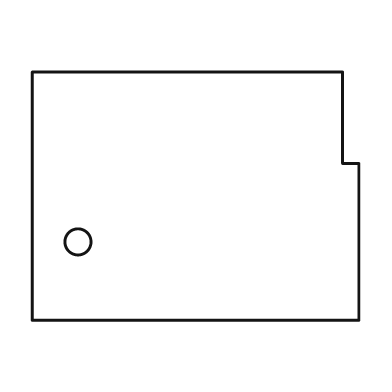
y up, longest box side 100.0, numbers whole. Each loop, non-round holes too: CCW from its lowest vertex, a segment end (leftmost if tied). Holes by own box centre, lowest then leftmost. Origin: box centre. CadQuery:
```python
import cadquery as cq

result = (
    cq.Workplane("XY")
    .moveTo(-50.0, -38.0)
    .lineTo(50.0, -38.0)
    .lineTo(50.0, 10.0)
    .lineTo(45.0, 10.0)
    .lineTo(45.0, 38.0)
    .lineTo(-50.0, 38.0)
    .close()
    .moveTo(-36.0, -14.0)
    .circle(4.0)
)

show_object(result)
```